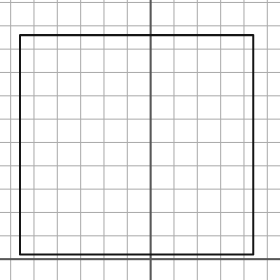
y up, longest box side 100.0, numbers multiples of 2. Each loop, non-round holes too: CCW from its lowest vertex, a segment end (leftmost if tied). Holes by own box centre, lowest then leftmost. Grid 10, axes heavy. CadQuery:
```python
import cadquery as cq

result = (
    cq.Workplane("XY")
    .moveTo(-56.0, 2.0)
    .lineTo(44.0, 2.0)
    .lineTo(44.0, 96.0)
    .lineTo(-56.0, 96.0)
    .close()
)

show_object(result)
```